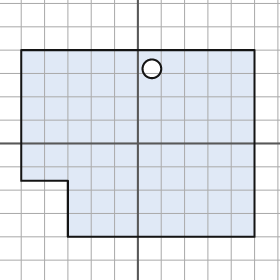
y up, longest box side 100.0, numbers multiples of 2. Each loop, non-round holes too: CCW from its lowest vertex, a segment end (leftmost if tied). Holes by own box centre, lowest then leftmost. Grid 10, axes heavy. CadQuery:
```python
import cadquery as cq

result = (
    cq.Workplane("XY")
    .moveTo(-30.0, -40.0)
    .lineTo(50.0, -40.0)
    .lineTo(50.0, 40.0)
    .lineTo(-50.0, 40.0)
    .lineTo(-50.0, -16.0)
    .lineTo(-30.0, -16.0)
    .close()
    .moveTo(6.0, 32.0)
    .circle(4.0)
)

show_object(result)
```